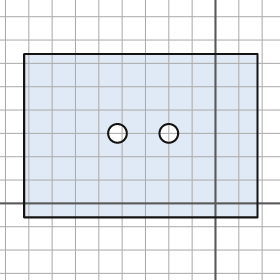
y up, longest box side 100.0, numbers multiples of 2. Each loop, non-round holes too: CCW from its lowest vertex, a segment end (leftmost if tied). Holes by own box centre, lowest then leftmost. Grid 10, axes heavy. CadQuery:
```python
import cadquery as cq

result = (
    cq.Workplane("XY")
    .moveTo(-82.0, -6.0)
    .lineTo(18.0, -6.0)
    .lineTo(18.0, 64.0)
    .lineTo(-82.0, 64.0)
    .close()
    .moveTo(-42.0, 30.0)
    .circle(4.0)
    .moveTo(-20.0, 30.0)
    .circle(4.0)
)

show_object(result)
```